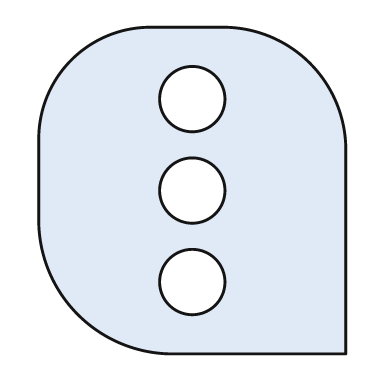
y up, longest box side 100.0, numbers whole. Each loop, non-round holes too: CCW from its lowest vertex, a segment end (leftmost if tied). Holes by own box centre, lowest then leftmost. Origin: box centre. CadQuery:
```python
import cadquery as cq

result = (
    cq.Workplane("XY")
    .moveTo(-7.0, -50.0)
    .lineTo(47.0, -50.0)
    .lineTo(47.0, 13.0)
    .threePointArc((36.0, 39.0), (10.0, 50.0))
    .lineTo(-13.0, 50.0)
    .threePointArc((-37.0, 40.0), (-47.0, 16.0))
    .lineTo(-47.0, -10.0)
    .threePointArc((-35.0, -38.0), (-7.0, -50.0))
    .close()
    .moveTo(0.0, -28.0)
    .circle(10.0)
    .moveTo(0.0, 0.0)
    .circle(10.0)
    .moveTo(0.0, 28.0)
    .circle(10.0)
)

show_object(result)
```